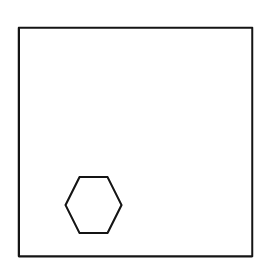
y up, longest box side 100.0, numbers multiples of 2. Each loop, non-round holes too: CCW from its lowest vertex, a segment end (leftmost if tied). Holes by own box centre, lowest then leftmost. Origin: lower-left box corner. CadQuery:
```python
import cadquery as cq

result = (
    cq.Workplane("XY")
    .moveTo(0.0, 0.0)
    .lineTo(100.0, 0.0)
    .lineTo(100.0, 98.0)
    .lineTo(0.0, 98.0)
    .close()
    .moveTo(26.0, 10.0)
    .lineTo(38.0, 10.0)
    .lineTo(44.0, 22.0)
    .lineTo(38.0, 34.0)
    .lineTo(26.0, 34.0)
    .lineTo(20.0, 22.0)
    .close()
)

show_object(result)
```